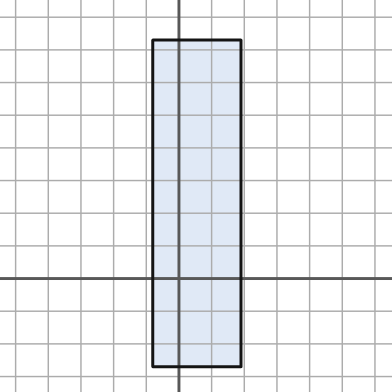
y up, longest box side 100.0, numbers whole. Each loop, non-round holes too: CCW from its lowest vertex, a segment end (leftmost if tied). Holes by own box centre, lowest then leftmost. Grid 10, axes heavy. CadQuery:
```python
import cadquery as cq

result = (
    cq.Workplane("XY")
    .moveTo(-8.0, -27.0)
    .lineTo(19.0, -27.0)
    .lineTo(19.0, 73.0)
    .lineTo(-8.0, 73.0)
    .close()
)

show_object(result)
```